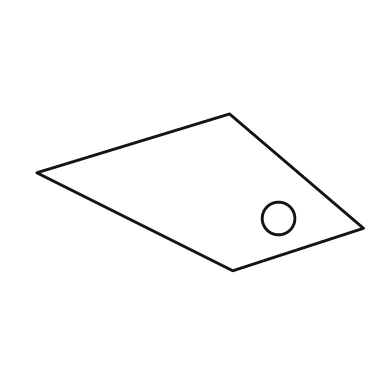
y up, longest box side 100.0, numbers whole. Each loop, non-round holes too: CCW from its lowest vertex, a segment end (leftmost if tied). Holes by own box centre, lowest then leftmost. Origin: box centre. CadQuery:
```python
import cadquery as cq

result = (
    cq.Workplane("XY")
    .moveTo(10.0, -24.0)
    .lineTo(50.0, -11.0)
    .lineTo(9.0, 24.0)
    .lineTo(-50.0, 6.0)
    .close()
    .moveTo(24.0, -8.0)
    .circle(5.0)
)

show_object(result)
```